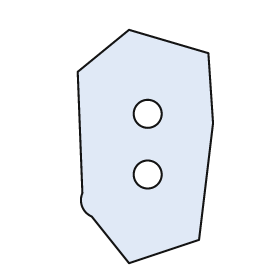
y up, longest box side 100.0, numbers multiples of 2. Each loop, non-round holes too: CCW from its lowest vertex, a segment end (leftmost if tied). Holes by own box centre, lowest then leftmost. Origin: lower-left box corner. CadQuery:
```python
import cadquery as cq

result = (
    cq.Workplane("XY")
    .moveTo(22.0, 0.0)
    .lineTo(52.0, 10.0)
    .lineTo(58.0, 60.0)
    .lineTo(56.0, 90.0)
    .lineTo(22.0, 100.0)
    .lineTo(0.0, 82.0)
    .lineTo(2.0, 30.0)
    .threePointArc((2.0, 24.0), (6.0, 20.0))
    .close()
    .moveTo(30.0, 38.0)
    .circle(6.0)
    .moveTo(30.0, 64.0)
    .circle(6.0)
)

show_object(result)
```